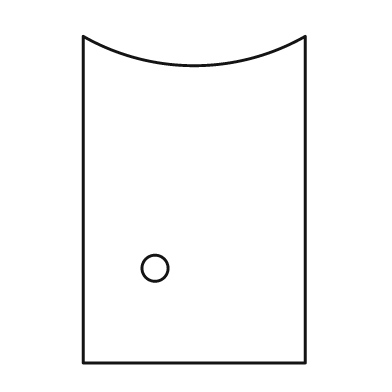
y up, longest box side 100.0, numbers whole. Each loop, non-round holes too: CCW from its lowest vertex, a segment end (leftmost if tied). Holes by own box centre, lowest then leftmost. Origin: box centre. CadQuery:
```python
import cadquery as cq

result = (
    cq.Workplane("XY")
    .moveTo(-34.0, -50.0)
    .lineTo(34.0, -50.0)
    .lineTo(34.0, 50.0)
    .threePointArc((0.0, 41.0), (-34.0, 50.0))
    .close()
    .moveTo(-12.0, -21.0)
    .circle(4.0)
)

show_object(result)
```